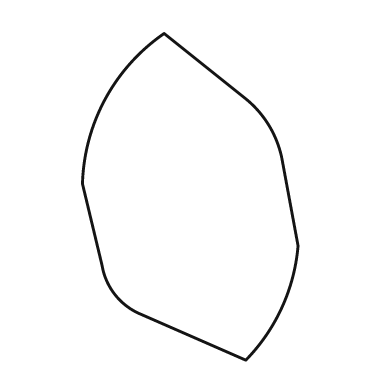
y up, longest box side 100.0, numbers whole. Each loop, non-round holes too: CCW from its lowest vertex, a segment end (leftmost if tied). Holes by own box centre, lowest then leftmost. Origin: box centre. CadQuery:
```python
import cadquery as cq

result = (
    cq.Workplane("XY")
    .moveTo(17.0, -50.0)
    .threePointArc((28.0, -34.0), (33.0, -15.0))
    .lineTo(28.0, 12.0)
    .threePointArc((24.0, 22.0), (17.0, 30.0))
    .lineTo(-8.0, 50.0)
    .threePointArc((-26.0, 30.0), (-33.0, 4.0))
    .lineTo(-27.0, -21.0)
    .threePointArc((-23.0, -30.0), (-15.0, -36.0))
    .close()
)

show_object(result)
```